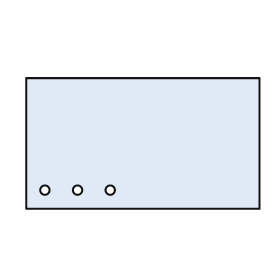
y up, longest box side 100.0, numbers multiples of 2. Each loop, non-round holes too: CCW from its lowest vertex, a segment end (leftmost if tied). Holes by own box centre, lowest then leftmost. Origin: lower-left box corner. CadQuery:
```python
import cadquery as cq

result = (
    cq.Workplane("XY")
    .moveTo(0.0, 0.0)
    .lineTo(100.0, 0.0)
    .lineTo(100.0, 56.0)
    .lineTo(0.0, 56.0)
    .close()
    .moveTo(8.0, 8.0)
    .circle(2.0)
    .moveTo(22.0, 8.0)
    .circle(2.0)
    .moveTo(36.0, 8.0)
    .circle(2.0)
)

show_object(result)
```